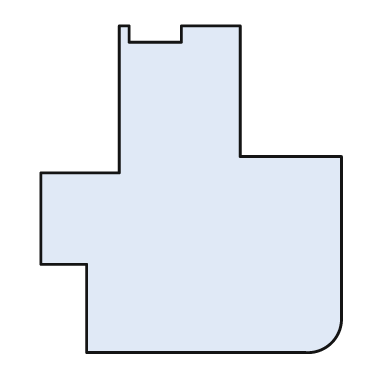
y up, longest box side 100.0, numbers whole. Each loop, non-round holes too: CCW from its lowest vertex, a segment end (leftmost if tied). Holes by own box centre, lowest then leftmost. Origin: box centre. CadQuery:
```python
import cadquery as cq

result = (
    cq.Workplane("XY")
    .moveTo(-32.0, -50.0)
    .lineTo(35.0, -50.0)
    .threePointArc((43.0, -47.0), (46.0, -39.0))
    .lineTo(46.0, 10.0)
    .lineTo(15.0, 10.0)
    .lineTo(15.0, 50.0)
    .lineTo(-3.0, 50.0)
    .lineTo(-3.0, 45.0)
    .lineTo(-19.0, 45.0)
    .lineTo(-19.0, 50.0)
    .lineTo(-22.0, 50.0)
    .lineTo(-22.0, 5.0)
    .lineTo(-46.0, 5.0)
    .lineTo(-46.0, -23.0)
    .lineTo(-32.0, -23.0)
    .close()
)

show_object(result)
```